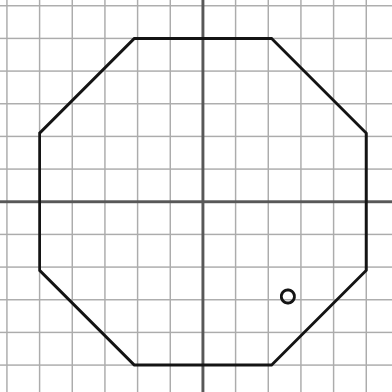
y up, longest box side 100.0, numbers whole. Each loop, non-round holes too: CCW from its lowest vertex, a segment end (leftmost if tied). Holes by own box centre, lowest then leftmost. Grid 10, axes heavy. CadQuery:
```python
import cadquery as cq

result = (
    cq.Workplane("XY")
    .moveTo(-21.0, -50.0)
    .lineTo(21.0, -50.0)
    .lineTo(50.0, -21.0)
    .lineTo(50.0, 21.0)
    .lineTo(21.0, 50.0)
    .lineTo(-21.0, 50.0)
    .lineTo(-50.0, 21.0)
    .lineTo(-50.0, -21.0)
    .close()
    .moveTo(26.0, -29.0)
    .circle(2.0)
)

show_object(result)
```